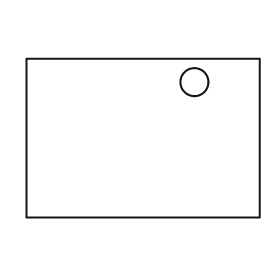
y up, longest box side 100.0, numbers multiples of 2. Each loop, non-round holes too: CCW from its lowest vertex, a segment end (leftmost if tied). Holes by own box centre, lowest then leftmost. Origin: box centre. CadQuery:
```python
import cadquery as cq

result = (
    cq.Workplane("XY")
    .moveTo(-50.0, -34.0)
    .lineTo(50.0, -34.0)
    .lineTo(50.0, 34.0)
    .lineTo(-50.0, 34.0)
    .close()
    .moveTo(22.0, 24.0)
    .circle(6.0)
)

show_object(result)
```